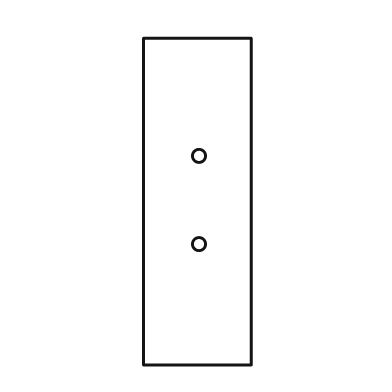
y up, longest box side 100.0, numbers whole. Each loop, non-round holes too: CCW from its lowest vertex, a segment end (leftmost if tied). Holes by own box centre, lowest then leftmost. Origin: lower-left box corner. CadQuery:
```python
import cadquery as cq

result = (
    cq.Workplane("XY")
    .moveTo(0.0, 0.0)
    .lineTo(33.0, 0.0)
    .lineTo(33.0, 100.0)
    .lineTo(0.0, 100.0)
    .close()
    .moveTo(17.0, 37.0)
    .circle(2.0)
    .moveTo(17.0, 64.0)
    .circle(2.0)
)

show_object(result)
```